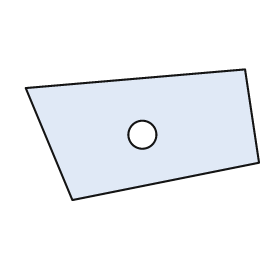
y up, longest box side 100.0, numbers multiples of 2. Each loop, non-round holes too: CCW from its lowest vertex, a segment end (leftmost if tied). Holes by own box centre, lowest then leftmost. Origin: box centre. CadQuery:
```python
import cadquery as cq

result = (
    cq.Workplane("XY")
    .moveTo(-30.0, -28.0)
    .lineTo(50.0, -12.0)
    .lineTo(44.0, 28.0)
    .lineTo(-50.0, 20.0)
    .close()
    .moveTo(0.0, 0.0)
    .circle(6.0)
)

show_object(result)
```